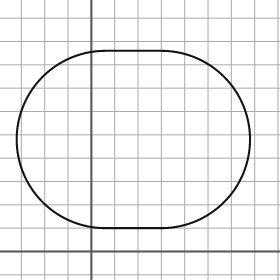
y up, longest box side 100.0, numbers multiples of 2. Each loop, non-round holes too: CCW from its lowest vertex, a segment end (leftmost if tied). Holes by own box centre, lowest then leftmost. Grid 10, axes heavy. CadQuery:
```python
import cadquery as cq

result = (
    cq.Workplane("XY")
    .moveTo(6.0, 10.0)
    .lineTo(30.0, 10.0)
    .threePointArc((68.0, 48.0), (30.0, 86.0))
    .lineTo(6.0, 86.0)
    .threePointArc((-32.0, 48.0), (6.0, 10.0))
    .close()
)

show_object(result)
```